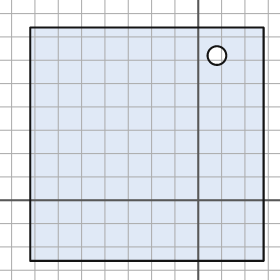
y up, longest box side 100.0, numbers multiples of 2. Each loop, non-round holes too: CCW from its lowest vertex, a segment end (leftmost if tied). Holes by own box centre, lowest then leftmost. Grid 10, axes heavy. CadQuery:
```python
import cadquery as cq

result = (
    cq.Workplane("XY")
    .moveTo(-72.0, -26.0)
    .lineTo(28.0, -26.0)
    .lineTo(28.0, 74.0)
    .lineTo(-72.0, 74.0)
    .close()
    .moveTo(8.0, 62.0)
    .circle(4.0)
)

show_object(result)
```